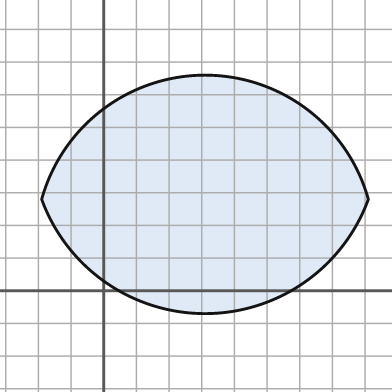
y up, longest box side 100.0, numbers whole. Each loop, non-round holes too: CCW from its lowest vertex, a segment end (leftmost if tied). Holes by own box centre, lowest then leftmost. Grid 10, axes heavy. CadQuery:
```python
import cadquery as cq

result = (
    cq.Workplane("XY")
    .moveTo(-19.0, 28.0)
    .threePointArc((31.0, -7.0), (81.0, 28.0))
    .threePointArc((31.0, 66.0), (-19.0, 28.0))
    .close()
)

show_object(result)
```